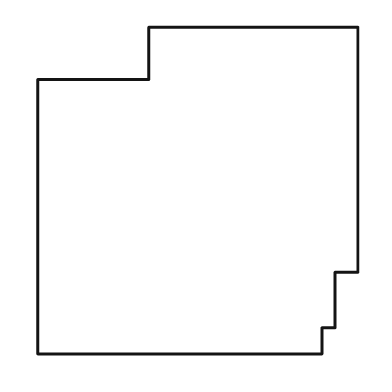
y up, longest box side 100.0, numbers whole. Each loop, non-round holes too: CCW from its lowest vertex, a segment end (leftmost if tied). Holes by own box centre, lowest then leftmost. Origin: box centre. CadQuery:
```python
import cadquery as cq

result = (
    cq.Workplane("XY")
    .moveTo(-49.0, -50.0)
    .lineTo(38.0, -50.0)
    .lineTo(38.0, -42.0)
    .lineTo(42.0, -42.0)
    .lineTo(42.0, -25.0)
    .lineTo(49.0, -25.0)
    .lineTo(49.0, 50.0)
    .lineTo(-15.0, 50.0)
    .lineTo(-15.0, 34.0)
    .lineTo(-49.0, 34.0)
    .close()
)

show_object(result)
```